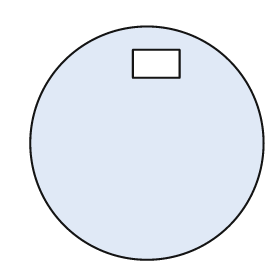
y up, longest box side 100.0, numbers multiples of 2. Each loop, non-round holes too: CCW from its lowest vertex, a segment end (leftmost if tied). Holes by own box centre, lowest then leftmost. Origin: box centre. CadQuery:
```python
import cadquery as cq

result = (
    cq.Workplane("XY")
    .moveTo(0.0, 0.0)
    .circle(50.0)
    .moveTo(-6.0, 28.0)
    .lineTo(14.0, 28.0)
    .lineTo(14.0, 40.0)
    .lineTo(-6.0, 40.0)
    .close()
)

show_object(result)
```